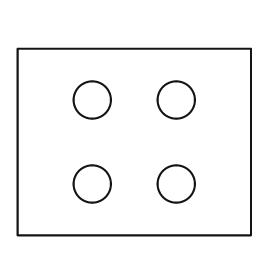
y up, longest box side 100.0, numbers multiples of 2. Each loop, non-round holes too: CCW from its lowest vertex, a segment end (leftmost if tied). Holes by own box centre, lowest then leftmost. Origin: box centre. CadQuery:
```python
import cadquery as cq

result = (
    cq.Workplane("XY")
    .moveTo(-50.0, -40.0)
    .lineTo(50.0, -40.0)
    .lineTo(50.0, 40.0)
    .lineTo(-50.0, 40.0)
    .close()
    .moveTo(-18.0, -18.0)
    .circle(8.0)
    .moveTo(18.0, -18.0)
    .circle(8.0)
    .moveTo(-18.0, 18.0)
    .circle(8.0)
    .moveTo(18.0, 18.0)
    .circle(8.0)
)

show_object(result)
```